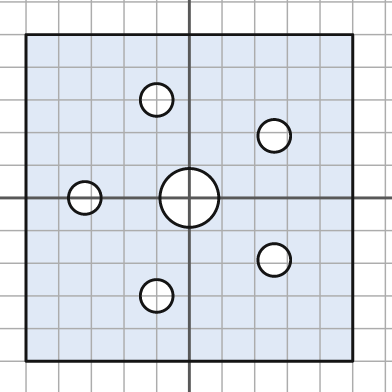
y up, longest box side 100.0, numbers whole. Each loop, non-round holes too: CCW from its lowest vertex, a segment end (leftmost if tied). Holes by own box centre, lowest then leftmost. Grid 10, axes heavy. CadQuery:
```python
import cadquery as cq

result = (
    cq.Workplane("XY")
    .moveTo(-50.0, -50.0)
    .lineTo(50.0, -50.0)
    .lineTo(50.0, 50.0)
    .lineTo(-50.0, 50.0)
    .close()
    .moveTo(-10.0, -30.0)
    .circle(5.0)
    .moveTo(26.0, -19.0)
    .circle(5.0)
    .moveTo(-32.0, 0.0)
    .circle(5.0)
    .moveTo(0.0, 0.0)
    .circle(9.0)
    .moveTo(26.0, 19.0)
    .circle(5.0)
    .moveTo(-10.0, 30.0)
    .circle(5.0)
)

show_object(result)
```